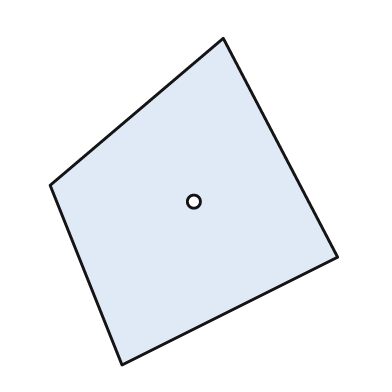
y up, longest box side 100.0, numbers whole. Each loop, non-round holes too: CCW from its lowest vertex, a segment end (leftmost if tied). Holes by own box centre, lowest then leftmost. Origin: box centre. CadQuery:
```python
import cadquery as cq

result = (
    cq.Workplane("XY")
    .moveTo(-22.0, -50.0)
    .lineTo(44.0, -17.0)
    .lineTo(9.0, 50.0)
    .lineTo(-44.0, 5.0)
    .close()
    .moveTo(0.0, 0.0)
    .circle(2.0)
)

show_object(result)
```